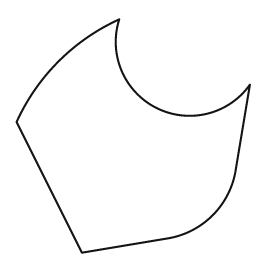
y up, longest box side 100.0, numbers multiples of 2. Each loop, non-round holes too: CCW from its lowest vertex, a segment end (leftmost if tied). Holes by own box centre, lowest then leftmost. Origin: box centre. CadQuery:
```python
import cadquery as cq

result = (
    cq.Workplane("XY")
    .moveTo(-22.0, -50.0)
    .lineTo(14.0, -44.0)
    .threePointArc((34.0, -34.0), (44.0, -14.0))
    .lineTo(50.0, 22.0)
    .threePointArc((10.0, 12.0), (-6.0, 50.0))
    .threePointArc((-32.0, 32.0), (-50.0, 6.0))
    .close()
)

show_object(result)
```